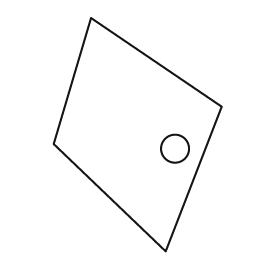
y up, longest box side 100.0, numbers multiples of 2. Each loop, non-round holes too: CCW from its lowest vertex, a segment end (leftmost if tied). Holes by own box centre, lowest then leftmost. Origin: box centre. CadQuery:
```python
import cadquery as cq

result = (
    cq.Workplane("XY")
    .moveTo(12.0, -50.0)
    .lineTo(36.0, 12.0)
    .lineTo(-20.0, 50.0)
    .lineTo(-36.0, -4.0)
    .close()
    .moveTo(16.0, -6.0)
    .circle(6.0)
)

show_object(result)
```